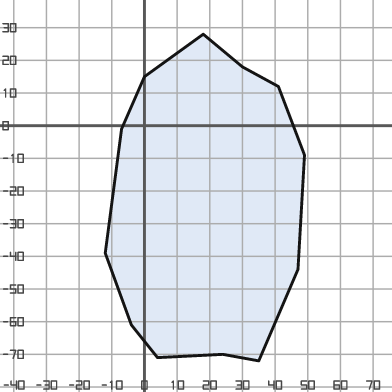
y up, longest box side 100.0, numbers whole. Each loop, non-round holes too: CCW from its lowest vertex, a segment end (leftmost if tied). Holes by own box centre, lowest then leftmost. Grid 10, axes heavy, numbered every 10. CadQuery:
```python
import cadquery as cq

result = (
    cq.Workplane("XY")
    .moveTo(35.0, -72.0)
    .lineTo(47.0, -44.0)
    .lineTo(49.0, -9.0)
    .lineTo(41.0, 12.0)
    .lineTo(30.0, 18.0)
    .lineTo(18.0, 28.0)
    .lineTo(0.0, 15.0)
    .lineTo(-7.0, -1.0)
    .lineTo(-12.0, -39.0)
    .lineTo(-4.0, -61.0)
    .lineTo(4.0, -71.0)
    .lineTo(24.0, -70.0)
    .close()
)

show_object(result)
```